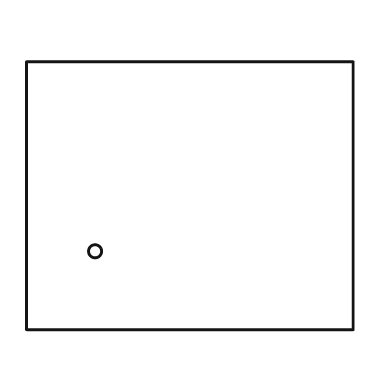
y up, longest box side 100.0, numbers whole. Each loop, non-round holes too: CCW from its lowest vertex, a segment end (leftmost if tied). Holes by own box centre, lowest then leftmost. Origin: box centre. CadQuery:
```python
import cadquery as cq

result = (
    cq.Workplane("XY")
    .moveTo(-50.0, -41.0)
    .lineTo(50.0, -41.0)
    .lineTo(50.0, 41.0)
    .lineTo(-50.0, 41.0)
    .close()
    .moveTo(-29.0, -17.0)
    .circle(2.0)
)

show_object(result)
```